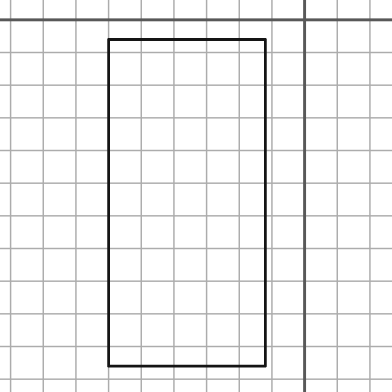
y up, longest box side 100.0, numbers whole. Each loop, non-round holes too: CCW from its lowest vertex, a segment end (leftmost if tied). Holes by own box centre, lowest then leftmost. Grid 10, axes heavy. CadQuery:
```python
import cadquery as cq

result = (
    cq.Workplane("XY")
    .moveTo(-60.0, -106.0)
    .lineTo(-12.0, -106.0)
    .lineTo(-12.0, -6.0)
    .lineTo(-60.0, -6.0)
    .close()
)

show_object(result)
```